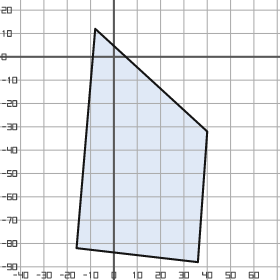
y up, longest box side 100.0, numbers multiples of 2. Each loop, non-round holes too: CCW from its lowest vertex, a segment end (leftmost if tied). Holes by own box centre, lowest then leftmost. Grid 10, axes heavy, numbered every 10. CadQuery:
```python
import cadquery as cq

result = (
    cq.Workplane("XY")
    .moveTo(36.0, -88.0)
    .lineTo(40.0, -32.0)
    .lineTo(-8.0, 12.0)
    .lineTo(-16.0, -82.0)
    .close()
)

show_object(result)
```